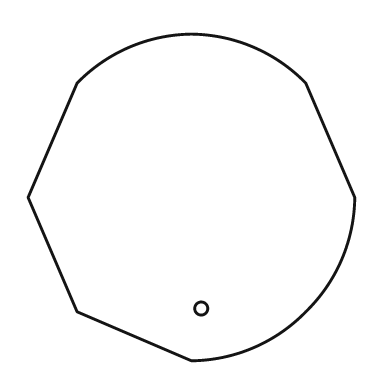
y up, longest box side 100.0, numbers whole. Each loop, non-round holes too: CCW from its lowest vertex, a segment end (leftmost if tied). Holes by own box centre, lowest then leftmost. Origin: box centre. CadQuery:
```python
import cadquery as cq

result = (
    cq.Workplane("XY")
    .moveTo(0.0, -50.0)
    .threePointArc((19.0, -46.0), (35.0, -35.0))
    .threePointArc((46.0, -19.0), (50.0, 0.0))
    .lineTo(35.0, 35.0)
    .threePointArc((19.0, 46.0), (0.0, 50.0))
    .threePointArc((-19.0, 46.0), (-35.0, 35.0))
    .lineTo(-50.0, 0.0)
    .lineTo(-35.0, -35.0)
    .close()
    .moveTo(3.0, -34.0)
    .circle(2.0)
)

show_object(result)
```